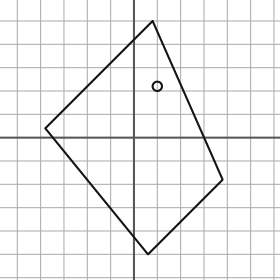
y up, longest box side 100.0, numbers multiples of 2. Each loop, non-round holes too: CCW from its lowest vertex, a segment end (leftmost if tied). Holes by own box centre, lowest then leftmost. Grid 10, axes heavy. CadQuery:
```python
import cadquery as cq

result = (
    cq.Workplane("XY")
    .moveTo(6.0, -50.0)
    .lineTo(38.0, -18.0)
    .lineTo(8.0, 50.0)
    .lineTo(-38.0, 4.0)
    .close()
    .moveTo(10.0, 22.0)
    .circle(2.0)
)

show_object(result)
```